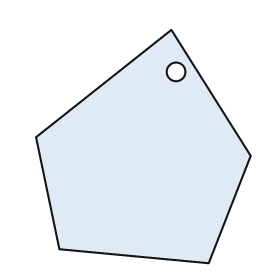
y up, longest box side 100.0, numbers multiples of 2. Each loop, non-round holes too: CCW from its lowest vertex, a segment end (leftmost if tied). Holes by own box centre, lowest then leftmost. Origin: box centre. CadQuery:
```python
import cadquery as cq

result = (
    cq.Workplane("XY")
    .moveTo(28.0, -50.0)
    .lineTo(46.0, -4.0)
    .lineTo(12.0, 50.0)
    .lineTo(-46.0, 4.0)
    .lineTo(-36.0, -44.0)
    .close()
    .moveTo(14.0, 32.0)
    .circle(4.0)
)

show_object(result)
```